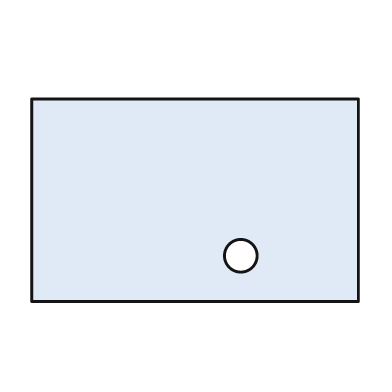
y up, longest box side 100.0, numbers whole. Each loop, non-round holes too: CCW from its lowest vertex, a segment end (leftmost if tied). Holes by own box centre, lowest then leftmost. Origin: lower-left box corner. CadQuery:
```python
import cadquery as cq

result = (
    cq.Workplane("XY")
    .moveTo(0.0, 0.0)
    .lineTo(100.0, 0.0)
    .lineTo(100.0, 62.0)
    .lineTo(0.0, 62.0)
    .close()
    .moveTo(64.0, 14.0)
    .circle(5.0)
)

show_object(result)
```